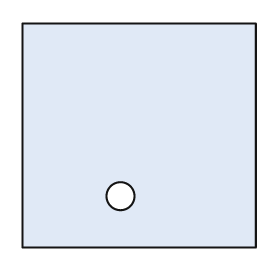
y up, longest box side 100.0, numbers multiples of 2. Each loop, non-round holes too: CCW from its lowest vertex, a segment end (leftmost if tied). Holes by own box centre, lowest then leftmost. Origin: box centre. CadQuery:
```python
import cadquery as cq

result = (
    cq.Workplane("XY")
    .moveTo(-50.0, -48.0)
    .lineTo(50.0, -48.0)
    .lineTo(50.0, 48.0)
    .lineTo(-50.0, 48.0)
    .close()
    .moveTo(-8.0, -26.0)
    .circle(6.0)
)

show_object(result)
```